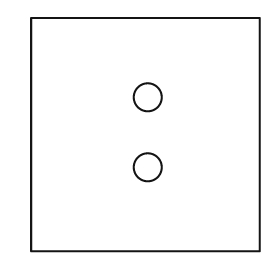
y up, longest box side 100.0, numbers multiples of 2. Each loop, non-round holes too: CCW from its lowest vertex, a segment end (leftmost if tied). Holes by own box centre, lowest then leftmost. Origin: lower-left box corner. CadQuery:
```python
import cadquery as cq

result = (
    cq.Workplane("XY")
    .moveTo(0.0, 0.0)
    .lineTo(98.0, 0.0)
    .lineTo(98.0, 100.0)
    .lineTo(0.0, 100.0)
    .close()
    .moveTo(50.0, 36.0)
    .circle(6.0)
    .moveTo(50.0, 66.0)
    .circle(6.0)
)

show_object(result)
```